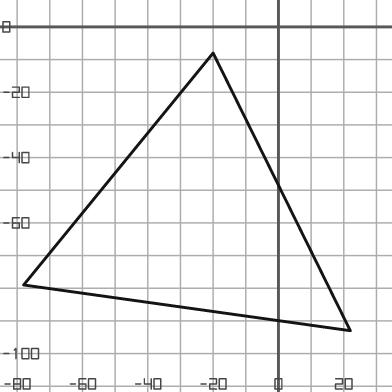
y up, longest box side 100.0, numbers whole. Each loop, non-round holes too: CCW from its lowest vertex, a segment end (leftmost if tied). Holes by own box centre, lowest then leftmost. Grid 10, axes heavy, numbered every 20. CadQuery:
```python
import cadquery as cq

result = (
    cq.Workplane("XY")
    .moveTo(22.0, -93.0)
    .lineTo(-20.0, -8.0)
    .lineTo(-78.0, -79.0)
    .close()
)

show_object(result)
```